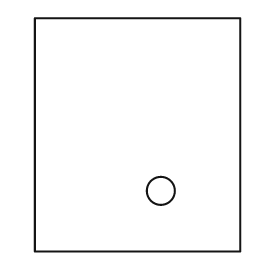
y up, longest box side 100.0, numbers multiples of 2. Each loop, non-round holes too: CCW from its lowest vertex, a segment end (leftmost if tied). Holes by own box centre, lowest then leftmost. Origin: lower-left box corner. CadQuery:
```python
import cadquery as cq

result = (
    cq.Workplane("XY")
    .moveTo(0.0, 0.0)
    .lineTo(88.0, 0.0)
    .lineTo(88.0, 100.0)
    .lineTo(0.0, 100.0)
    .close()
    .moveTo(54.0, 26.0)
    .circle(6.0)
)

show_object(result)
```